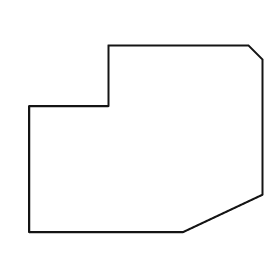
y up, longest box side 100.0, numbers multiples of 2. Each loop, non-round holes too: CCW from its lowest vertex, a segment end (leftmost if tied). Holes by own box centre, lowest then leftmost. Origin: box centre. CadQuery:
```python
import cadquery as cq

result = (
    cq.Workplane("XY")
    .moveTo(-50.0, -40.0)
    .lineTo(16.0, -40.0)
    .lineTo(50.0, -24.0)
    .lineTo(50.0, 34.0)
    .lineTo(44.0, 40.0)
    .lineTo(-16.0, 40.0)
    .lineTo(-16.0, 14.0)
    .lineTo(-50.0, 14.0)
    .close()
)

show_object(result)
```